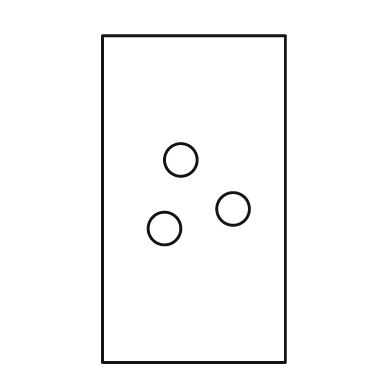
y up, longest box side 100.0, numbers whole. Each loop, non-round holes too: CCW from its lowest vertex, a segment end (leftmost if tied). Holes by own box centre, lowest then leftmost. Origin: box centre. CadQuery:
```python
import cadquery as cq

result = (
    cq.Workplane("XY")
    .moveTo(-28.0, -50.0)
    .lineTo(28.0, -50.0)
    .lineTo(28.0, 50.0)
    .lineTo(-28.0, 50.0)
    .close()
    .moveTo(-9.0, -9.0)
    .circle(5.0)
    .moveTo(12.0, -3.0)
    .circle(5.0)
    .moveTo(-4.0, 12.0)
    .circle(5.0)
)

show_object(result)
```